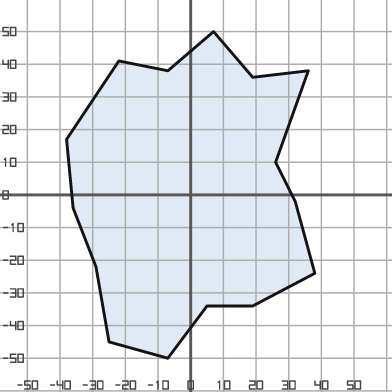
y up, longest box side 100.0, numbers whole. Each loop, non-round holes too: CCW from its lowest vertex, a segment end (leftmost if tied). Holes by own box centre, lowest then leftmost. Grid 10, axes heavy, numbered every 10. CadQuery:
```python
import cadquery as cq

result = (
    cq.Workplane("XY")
    .moveTo(-7.0, -50.0)
    .lineTo(5.0, -34.0)
    .lineTo(19.0, -34.0)
    .lineTo(38.0, -24.0)
    .lineTo(32.0, -2.0)
    .lineTo(26.0, 10.0)
    .lineTo(36.0, 38.0)
    .lineTo(19.0, 36.0)
    .lineTo(7.0, 50.0)
    .lineTo(-7.0, 38.0)
    .lineTo(-22.0, 41.0)
    .lineTo(-38.0, 17.0)
    .lineTo(-36.0, -4.0)
    .lineTo(-29.0, -22.0)
    .lineTo(-25.0, -45.0)
    .close()
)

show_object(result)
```